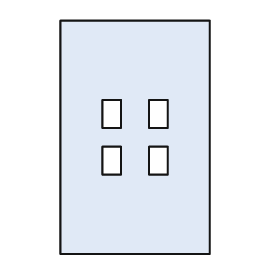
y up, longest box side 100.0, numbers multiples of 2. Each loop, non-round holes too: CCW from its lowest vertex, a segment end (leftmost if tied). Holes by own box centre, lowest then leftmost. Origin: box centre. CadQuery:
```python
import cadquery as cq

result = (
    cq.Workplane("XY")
    .moveTo(-32.0, -50.0)
    .lineTo(32.0, -50.0)
    .lineTo(32.0, 50.0)
    .lineTo(-32.0, 50.0)
    .close()
    .moveTo(-14.0, -16.0)
    .lineTo(-6.0, -16.0)
    .lineTo(-6.0, -4.0)
    .lineTo(-14.0, -4.0)
    .close()
    .moveTo(6.0, -16.0)
    .lineTo(14.0, -16.0)
    .lineTo(14.0, -4.0)
    .lineTo(6.0, -4.0)
    .close()
    .moveTo(-14.0, 4.0)
    .lineTo(-6.0, 4.0)
    .lineTo(-6.0, 16.0)
    .lineTo(-14.0, 16.0)
    .close()
    .moveTo(6.0, 4.0)
    .lineTo(14.0, 4.0)
    .lineTo(14.0, 16.0)
    .lineTo(6.0, 16.0)
    .close()
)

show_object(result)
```